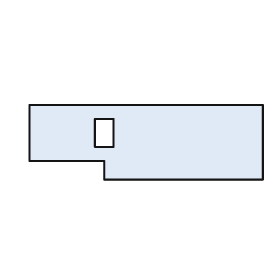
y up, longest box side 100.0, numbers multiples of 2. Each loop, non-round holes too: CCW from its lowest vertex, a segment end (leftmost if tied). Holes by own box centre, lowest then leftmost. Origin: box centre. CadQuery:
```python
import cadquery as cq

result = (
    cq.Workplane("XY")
    .moveTo(-18.0, -16.0)
    .lineTo(50.0, -16.0)
    .lineTo(50.0, 16.0)
    .lineTo(-50.0, 16.0)
    .lineTo(-50.0, -8.0)
    .lineTo(-18.0, -8.0)
    .close()
    .moveTo(-22.0, -2.0)
    .lineTo(-14.0, -2.0)
    .lineTo(-14.0, 10.0)
    .lineTo(-22.0, 10.0)
    .close()
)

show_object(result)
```